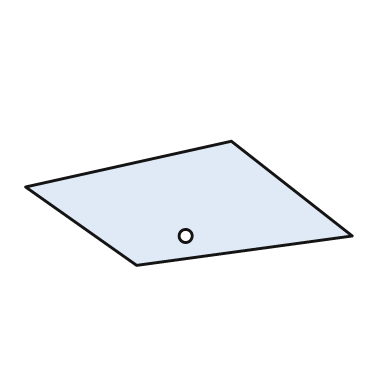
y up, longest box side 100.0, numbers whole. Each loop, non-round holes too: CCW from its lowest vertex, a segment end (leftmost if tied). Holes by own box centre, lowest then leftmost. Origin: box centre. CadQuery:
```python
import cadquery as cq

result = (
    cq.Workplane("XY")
    .moveTo(-16.0, -19.0)
    .lineTo(50.0, -10.0)
    .lineTo(13.0, 19.0)
    .lineTo(-50.0, 5.0)
    .close()
    .moveTo(-1.0, -10.0)
    .circle(2.0)
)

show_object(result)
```